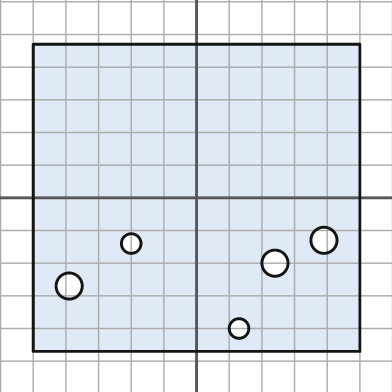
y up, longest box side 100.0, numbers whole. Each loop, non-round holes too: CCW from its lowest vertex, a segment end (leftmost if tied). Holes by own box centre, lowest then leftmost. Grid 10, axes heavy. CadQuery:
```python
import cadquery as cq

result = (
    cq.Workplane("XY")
    .moveTo(-50.0, -47.0)
    .lineTo(50.0, -47.0)
    .lineTo(50.0, 47.0)
    .lineTo(-50.0, 47.0)
    .close()
    .moveTo(13.0, -40.0)
    .circle(3.0)
    .moveTo(-39.0, -27.0)
    .circle(4.0)
    .moveTo(24.0, -20.0)
    .circle(4.0)
    .moveTo(-20.0, -14.0)
    .circle(3.0)
    .moveTo(39.0, -13.0)
    .circle(4.0)
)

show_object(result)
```